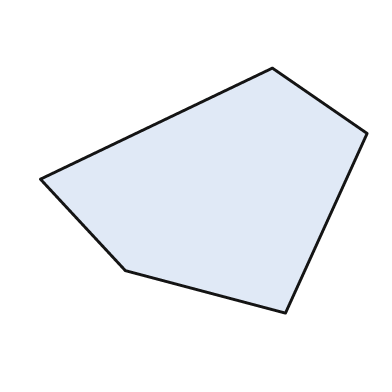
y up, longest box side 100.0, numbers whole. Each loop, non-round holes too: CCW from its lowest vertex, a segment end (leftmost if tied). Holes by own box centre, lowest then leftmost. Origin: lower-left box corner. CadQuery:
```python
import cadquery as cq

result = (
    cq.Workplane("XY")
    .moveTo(75.0, 0.0)
    .lineTo(100.0, 55.0)
    .lineTo(71.0, 75.0)
    .lineTo(0.0, 41.0)
    .lineTo(26.0, 13.0)
    .close()
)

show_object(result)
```